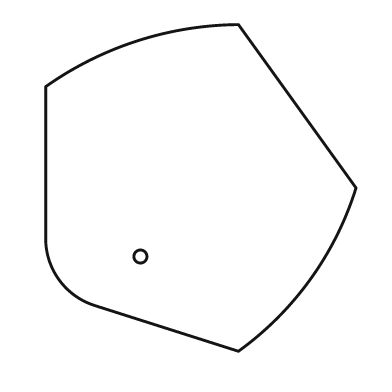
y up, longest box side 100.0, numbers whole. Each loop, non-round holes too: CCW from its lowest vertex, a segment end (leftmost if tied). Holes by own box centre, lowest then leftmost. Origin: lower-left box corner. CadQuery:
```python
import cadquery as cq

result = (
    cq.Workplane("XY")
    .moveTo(59.0, 0.0)
    .threePointArc((81.0, 22.0), (95.0, 50.0))
    .lineTo(59.0, 100.0)
    .threePointArc((28.0, 95.0), (0.0, 81.0))
    .lineTo(0.0, 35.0)
    .threePointArc((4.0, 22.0), (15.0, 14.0))
    .close()
    .moveTo(29.0, 29.0)
    .circle(2.0)
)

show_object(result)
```